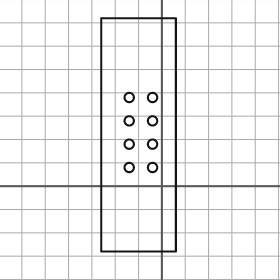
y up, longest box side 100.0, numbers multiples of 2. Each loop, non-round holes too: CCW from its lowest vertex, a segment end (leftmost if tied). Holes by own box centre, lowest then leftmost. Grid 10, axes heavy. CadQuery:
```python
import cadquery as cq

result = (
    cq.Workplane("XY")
    .moveTo(-26.0, -28.0)
    .lineTo(6.0, -28.0)
    .lineTo(6.0, 72.0)
    .lineTo(-26.0, 72.0)
    .close()
    .moveTo(-14.0, 8.0)
    .circle(2.0)
    .moveTo(-4.0, 8.0)
    .circle(2.0)
    .moveTo(-14.0, 18.0)
    .circle(2.0)
    .moveTo(-4.0, 18.0)
    .circle(2.0)
    .moveTo(-14.0, 28.0)
    .circle(2.0)
    .moveTo(-4.0, 28.0)
    .circle(2.0)
    .moveTo(-14.0, 38.0)
    .circle(2.0)
    .moveTo(-4.0, 38.0)
    .circle(2.0)
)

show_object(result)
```